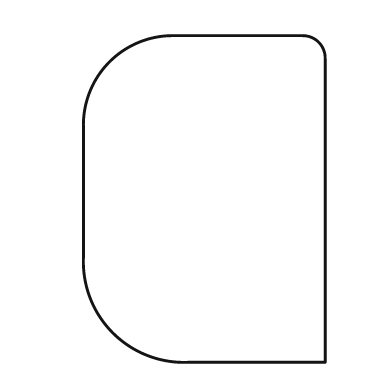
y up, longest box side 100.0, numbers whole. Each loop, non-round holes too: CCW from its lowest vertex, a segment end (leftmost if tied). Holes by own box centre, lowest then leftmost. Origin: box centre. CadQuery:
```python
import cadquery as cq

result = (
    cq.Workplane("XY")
    .moveTo(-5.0, -50.0)
    .lineTo(37.0, -50.0)
    .lineTo(37.0, 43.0)
    .threePointArc((35.0, 48.0), (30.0, 50.0))
    .lineTo(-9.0, 50.0)
    .threePointArc((-29.0, 42.0), (-37.0, 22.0))
    .lineTo(-37.0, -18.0)
    .threePointArc((-28.0, -41.0), (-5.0, -50.0))
    .close()
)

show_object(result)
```